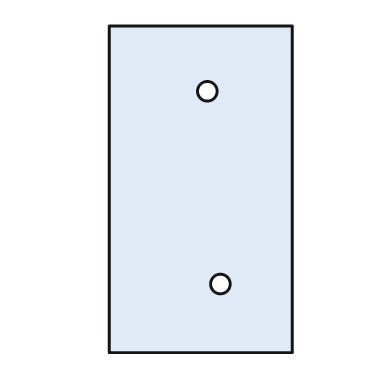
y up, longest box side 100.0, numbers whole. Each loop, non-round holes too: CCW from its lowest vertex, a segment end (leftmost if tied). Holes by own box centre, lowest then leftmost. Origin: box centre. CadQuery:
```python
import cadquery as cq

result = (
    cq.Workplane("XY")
    .moveTo(-28.0, -50.0)
    .lineTo(28.0, -50.0)
    .lineTo(28.0, 50.0)
    .lineTo(-28.0, 50.0)
    .close()
    .moveTo(6.0, -29.0)
    .circle(3.0)
    .moveTo(2.0, 30.0)
    .circle(3.0)
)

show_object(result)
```